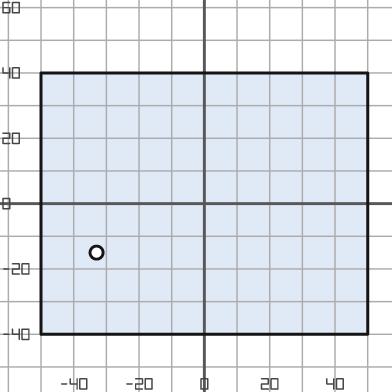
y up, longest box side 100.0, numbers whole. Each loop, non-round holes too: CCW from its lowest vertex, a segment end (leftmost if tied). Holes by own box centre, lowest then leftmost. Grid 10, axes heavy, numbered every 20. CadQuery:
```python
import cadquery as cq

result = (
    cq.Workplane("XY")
    .moveTo(-50.0, -40.0)
    .lineTo(50.0, -40.0)
    .lineTo(50.0, 40.0)
    .lineTo(-50.0, 40.0)
    .close()
    .moveTo(-33.0, -15.0)
    .circle(2.0)
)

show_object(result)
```